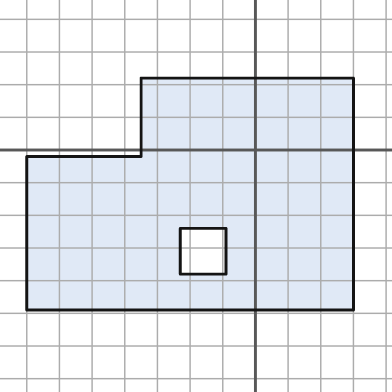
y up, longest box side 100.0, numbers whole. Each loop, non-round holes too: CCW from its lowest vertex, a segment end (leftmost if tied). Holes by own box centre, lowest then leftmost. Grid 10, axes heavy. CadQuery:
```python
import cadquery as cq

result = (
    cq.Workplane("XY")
    .moveTo(-70.0, -49.0)
    .lineTo(30.0, -49.0)
    .lineTo(30.0, 22.0)
    .lineTo(-35.0, 22.0)
    .lineTo(-35.0, -2.0)
    .lineTo(-70.0, -2.0)
    .close()
    .moveTo(-23.0, -38.0)
    .lineTo(-9.0, -38.0)
    .lineTo(-9.0, -24.0)
    .lineTo(-23.0, -24.0)
    .close()
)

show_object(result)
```